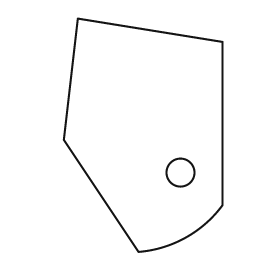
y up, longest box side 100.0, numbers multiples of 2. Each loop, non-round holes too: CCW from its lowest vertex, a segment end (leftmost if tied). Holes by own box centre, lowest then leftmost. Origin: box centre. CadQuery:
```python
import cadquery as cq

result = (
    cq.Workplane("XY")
    .moveTo(-2.0, -50.0)
    .threePointArc((18.0, -44.0), (34.0, -30.0))
    .lineTo(34.0, 40.0)
    .lineTo(-28.0, 50.0)
    .lineTo(-34.0, -2.0)
    .close()
    .moveTo(16.0, -16.0)
    .circle(6.0)
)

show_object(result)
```